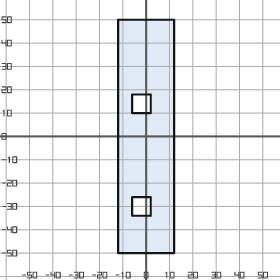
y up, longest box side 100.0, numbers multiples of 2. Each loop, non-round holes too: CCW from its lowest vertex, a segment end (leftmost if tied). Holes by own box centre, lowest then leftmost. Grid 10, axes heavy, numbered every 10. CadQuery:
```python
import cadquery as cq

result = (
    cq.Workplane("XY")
    .moveTo(-12.0, -50.0)
    .lineTo(12.0, -50.0)
    .lineTo(12.0, 50.0)
    .lineTo(-12.0, 50.0)
    .close()
    .moveTo(-6.0, -34.0)
    .lineTo(2.0, -34.0)
    .lineTo(2.0, -26.0)
    .lineTo(-6.0, -26.0)
    .close()
    .moveTo(-6.0, 10.0)
    .lineTo(2.0, 10.0)
    .lineTo(2.0, 18.0)
    .lineTo(-6.0, 18.0)
    .close()
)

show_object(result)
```